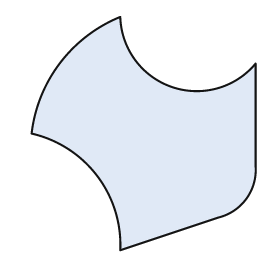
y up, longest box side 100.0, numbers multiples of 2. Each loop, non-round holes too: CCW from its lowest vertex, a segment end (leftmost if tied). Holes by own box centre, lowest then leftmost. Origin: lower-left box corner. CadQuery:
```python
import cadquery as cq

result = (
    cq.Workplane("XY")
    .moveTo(38.0, 0.0)
    .lineTo(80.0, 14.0)
    .threePointArc((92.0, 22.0), (96.0, 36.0))
    .lineTo(96.0, 80.0)
    .threePointArc((60.0, 70.0), (38.0, 100.0))
    .threePointArc((12.0, 80.0), (0.0, 50.0))
    .threePointArc((28.0, 32.0), (38.0, 0.0))
    .close()
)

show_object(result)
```